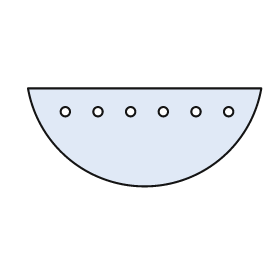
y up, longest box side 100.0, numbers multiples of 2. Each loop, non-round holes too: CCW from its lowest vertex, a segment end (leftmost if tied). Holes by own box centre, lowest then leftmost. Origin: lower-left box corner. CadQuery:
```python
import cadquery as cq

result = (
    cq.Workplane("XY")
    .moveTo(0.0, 42.0)
    .threePointArc((50.0, 0.0), (100.0, 42.0))
    .close()
    .moveTo(16.0, 32.0)
    .circle(2.0)
    .moveTo(30.0, 32.0)
    .circle(2.0)
    .moveTo(44.0, 32.0)
    .circle(2.0)
    .moveTo(58.0, 32.0)
    .circle(2.0)
    .moveTo(72.0, 32.0)
    .circle(2.0)
    .moveTo(86.0, 32.0)
    .circle(2.0)
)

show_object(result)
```